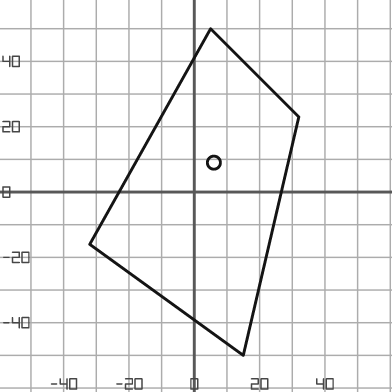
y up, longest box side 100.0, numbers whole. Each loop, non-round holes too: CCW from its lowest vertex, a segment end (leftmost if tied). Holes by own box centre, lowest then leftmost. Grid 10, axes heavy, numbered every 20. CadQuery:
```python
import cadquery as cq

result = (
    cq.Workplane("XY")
    .moveTo(15.0, -50.0)
    .lineTo(32.0, 23.0)
    .lineTo(5.0, 50.0)
    .lineTo(-32.0, -16.0)
    .close()
    .moveTo(6.0, 9.0)
    .circle(2.0)
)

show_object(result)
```